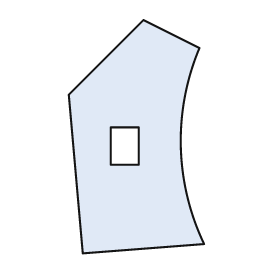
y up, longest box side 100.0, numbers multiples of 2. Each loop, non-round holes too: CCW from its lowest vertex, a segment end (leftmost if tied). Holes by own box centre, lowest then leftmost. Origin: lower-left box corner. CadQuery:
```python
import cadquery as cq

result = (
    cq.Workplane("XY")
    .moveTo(6.0, 0.0)
    .lineTo(58.0, 4.0)
    .threePointArc((48.0, 46.0), (56.0, 88.0))
    .lineTo(32.0, 100.0)
    .lineTo(0.0, 68.0)
    .close()
    .moveTo(18.0, 38.0)
    .lineTo(30.0, 38.0)
    .lineTo(30.0, 54.0)
    .lineTo(18.0, 54.0)
    .close()
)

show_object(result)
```